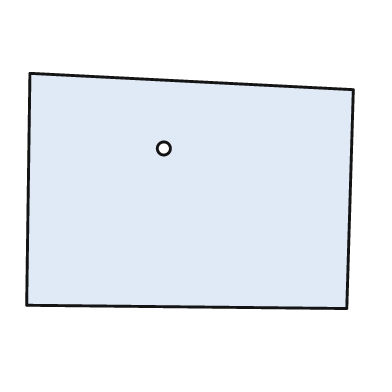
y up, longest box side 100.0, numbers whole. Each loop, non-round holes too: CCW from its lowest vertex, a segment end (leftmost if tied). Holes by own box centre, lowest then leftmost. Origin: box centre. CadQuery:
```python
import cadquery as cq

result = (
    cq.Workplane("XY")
    .moveTo(48.0, -36.0)
    .lineTo(50.0, 31.0)
    .lineTo(-49.0, 36.0)
    .lineTo(-50.0, -35.0)
    .close()
    .moveTo(-8.0, 13.0)
    .circle(2.0)
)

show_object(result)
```